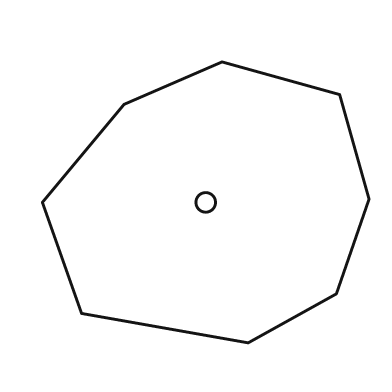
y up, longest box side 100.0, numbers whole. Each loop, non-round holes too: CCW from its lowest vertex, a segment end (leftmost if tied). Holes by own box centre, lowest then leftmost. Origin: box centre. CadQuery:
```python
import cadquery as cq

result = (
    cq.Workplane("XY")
    .moveTo(13.0, -43.0)
    .lineTo(40.0, -28.0)
    .lineTo(50.0, 1.0)
    .lineTo(41.0, 33.0)
    .lineTo(5.0, 43.0)
    .lineTo(-25.0, 30.0)
    .lineTo(-50.0, 0.0)
    .lineTo(-38.0, -34.0)
    .close()
    .moveTo(0.0, 0.0)
    .circle(3.0)
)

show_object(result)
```